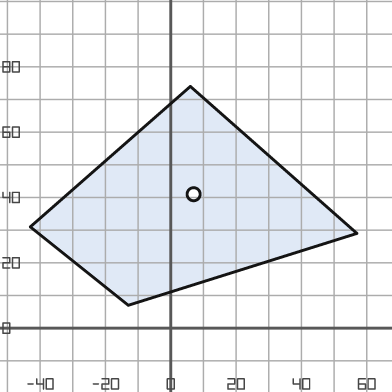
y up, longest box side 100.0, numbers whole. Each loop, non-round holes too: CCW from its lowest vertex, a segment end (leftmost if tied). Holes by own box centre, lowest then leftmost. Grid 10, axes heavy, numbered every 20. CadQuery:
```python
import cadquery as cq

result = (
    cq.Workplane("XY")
    .moveTo(-13.0, 7.0)
    .lineTo(57.0, 29.0)
    .lineTo(6.0, 74.0)
    .lineTo(-43.0, 31.0)
    .close()
    .moveTo(7.0, 41.0)
    .circle(2.0)
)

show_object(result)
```